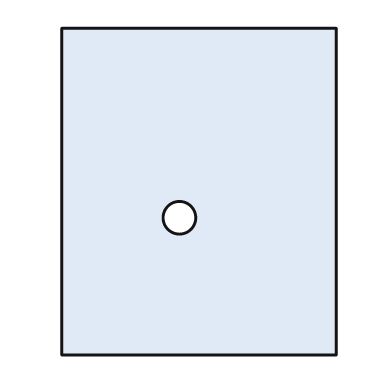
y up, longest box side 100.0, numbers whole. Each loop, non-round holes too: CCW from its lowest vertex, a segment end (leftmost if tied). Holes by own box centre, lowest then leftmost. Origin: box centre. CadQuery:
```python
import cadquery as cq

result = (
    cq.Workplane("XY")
    .moveTo(-42.0, -50.0)
    .lineTo(42.0, -50.0)
    .lineTo(42.0, 50.0)
    .lineTo(-42.0, 50.0)
    .close()
    .moveTo(-6.0, -8.0)
    .circle(5.0)
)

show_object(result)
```